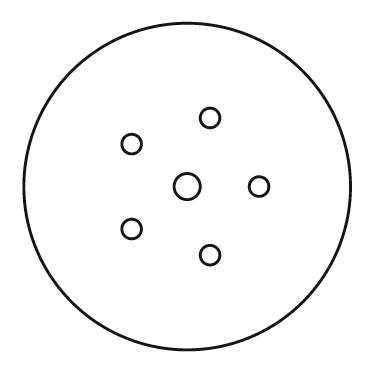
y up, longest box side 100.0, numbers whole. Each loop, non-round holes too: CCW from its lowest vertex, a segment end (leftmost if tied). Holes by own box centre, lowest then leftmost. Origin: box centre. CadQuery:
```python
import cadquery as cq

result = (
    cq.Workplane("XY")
    .moveTo(0.0, 0.0)
    .circle(50.0)
    .moveTo(7.0, -21.0)
    .circle(3.0)
    .moveTo(-17.0, -13.0)
    .circle(3.0)
    .moveTo(0.0, 0.0)
    .circle(4.0)
    .moveTo(22.0, 0.0)
    .circle(3.0)
    .moveTo(-17.0, 13.0)
    .circle(3.0)
    .moveTo(7.0, 21.0)
    .circle(3.0)
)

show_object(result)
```